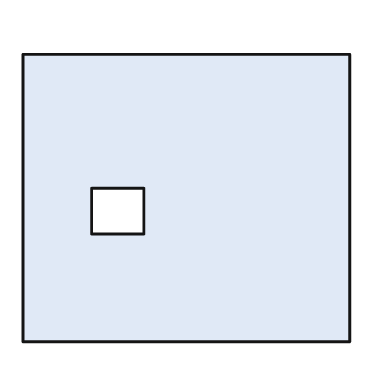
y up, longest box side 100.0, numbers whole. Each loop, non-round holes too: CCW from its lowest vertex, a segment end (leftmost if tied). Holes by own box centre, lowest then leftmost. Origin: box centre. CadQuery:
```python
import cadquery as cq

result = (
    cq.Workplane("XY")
    .moveTo(-50.0, -44.0)
    .lineTo(50.0, -44.0)
    .lineTo(50.0, 44.0)
    .lineTo(-50.0, 44.0)
    .close()
    .moveTo(-29.0, -11.0)
    .lineTo(-13.0, -11.0)
    .lineTo(-13.0, 3.0)
    .lineTo(-29.0, 3.0)
    .close()
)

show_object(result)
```